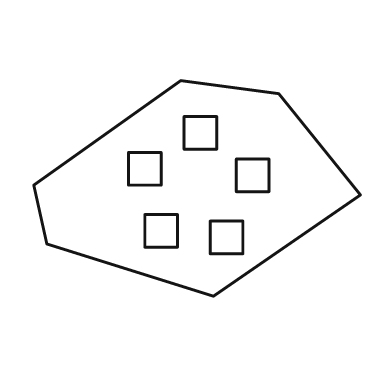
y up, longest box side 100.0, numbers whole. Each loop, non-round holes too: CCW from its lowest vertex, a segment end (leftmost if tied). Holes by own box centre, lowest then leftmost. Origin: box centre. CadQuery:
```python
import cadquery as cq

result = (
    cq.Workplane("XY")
    .moveTo(5.0, -33.0)
    .lineTo(50.0, -2.0)
    .lineTo(25.0, 29.0)
    .lineTo(-5.0, 33.0)
    .lineTo(-50.0, 1.0)
    .lineTo(-46.0, -17.0)
    .close()
    .moveTo(4.0, -20.0)
    .lineTo(14.0, -20.0)
    .lineTo(14.0, -10.0)
    .lineTo(4.0, -10.0)
    .close()
    .moveTo(-16.0, -18.0)
    .lineTo(-6.0, -18.0)
    .lineTo(-6.0, -8.0)
    .lineTo(-16.0, -8.0)
    .close()
    .moveTo(12.0, -1.0)
    .lineTo(22.0, -1.0)
    .lineTo(22.0, 9.0)
    .lineTo(12.0, 9.0)
    .close()
    .moveTo(-21.0, 1.0)
    .lineTo(-11.0, 1.0)
    .lineTo(-11.0, 11.0)
    .lineTo(-21.0, 11.0)
    .close()
    .moveTo(-4.0, 12.0)
    .lineTo(6.0, 12.0)
    .lineTo(6.0, 22.0)
    .lineTo(-4.0, 22.0)
    .close()
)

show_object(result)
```